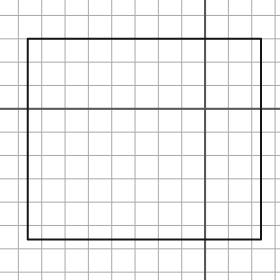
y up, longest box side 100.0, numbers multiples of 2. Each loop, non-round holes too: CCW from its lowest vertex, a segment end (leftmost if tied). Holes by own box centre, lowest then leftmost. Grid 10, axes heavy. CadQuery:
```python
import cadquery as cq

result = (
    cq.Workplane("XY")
    .moveTo(-76.0, -56.0)
    .lineTo(24.0, -56.0)
    .lineTo(24.0, 30.0)
    .lineTo(-76.0, 30.0)
    .close()
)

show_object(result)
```